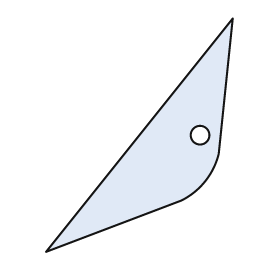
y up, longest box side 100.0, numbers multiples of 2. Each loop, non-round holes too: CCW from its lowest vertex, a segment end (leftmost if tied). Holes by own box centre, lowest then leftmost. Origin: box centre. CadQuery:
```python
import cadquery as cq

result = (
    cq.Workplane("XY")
    .moveTo(-40.0, -50.0)
    .lineTo(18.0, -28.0)
    .threePointArc((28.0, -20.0), (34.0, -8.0))
    .lineTo(40.0, 50.0)
    .close()
    .moveTo(26.0, 0.0)
    .circle(4.0)
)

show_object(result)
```